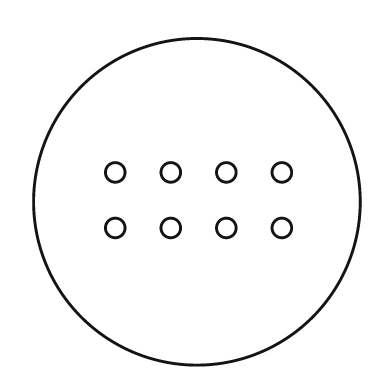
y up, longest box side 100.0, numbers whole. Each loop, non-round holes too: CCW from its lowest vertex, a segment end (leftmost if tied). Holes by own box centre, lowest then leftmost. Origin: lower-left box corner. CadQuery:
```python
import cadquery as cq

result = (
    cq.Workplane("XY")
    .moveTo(50.0, 50.0)
    .circle(50.0)
    .moveTo(25.0, 42.0)
    .circle(3.0)
    .moveTo(42.0, 42.0)
    .circle(3.0)
    .moveTo(59.0, 42.0)
    .circle(3.0)
    .moveTo(76.0, 42.0)
    .circle(3.0)
    .moveTo(25.0, 59.0)
    .circle(3.0)
    .moveTo(42.0, 59.0)
    .circle(3.0)
    .moveTo(59.0, 59.0)
    .circle(3.0)
    .moveTo(76.0, 59.0)
    .circle(3.0)
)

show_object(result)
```